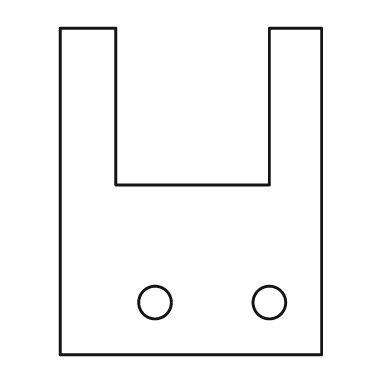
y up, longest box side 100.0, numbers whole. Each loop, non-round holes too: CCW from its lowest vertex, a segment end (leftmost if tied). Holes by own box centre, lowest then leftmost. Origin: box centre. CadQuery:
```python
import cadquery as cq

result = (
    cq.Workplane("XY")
    .moveTo(-40.0, -50.0)
    .lineTo(40.0, -50.0)
    .lineTo(40.0, 50.0)
    .lineTo(24.0, 50.0)
    .lineTo(24.0, 2.0)
    .lineTo(-23.0, 2.0)
    .lineTo(-23.0, 50.0)
    .lineTo(-40.0, 50.0)
    .close()
    .moveTo(-11.0, -34.0)
    .circle(5.0)
    .moveTo(24.0, -34.0)
    .circle(5.0)
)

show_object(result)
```